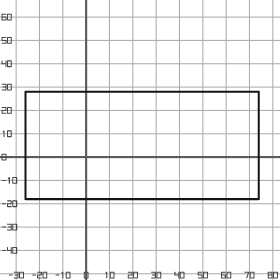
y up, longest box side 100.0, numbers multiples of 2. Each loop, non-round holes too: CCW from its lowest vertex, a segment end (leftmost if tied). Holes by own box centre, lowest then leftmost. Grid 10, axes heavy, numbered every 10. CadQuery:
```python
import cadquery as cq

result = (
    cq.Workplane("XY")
    .moveTo(-26.0, -18.0)
    .lineTo(74.0, -18.0)
    .lineTo(74.0, 28.0)
    .lineTo(-26.0, 28.0)
    .close()
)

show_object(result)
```